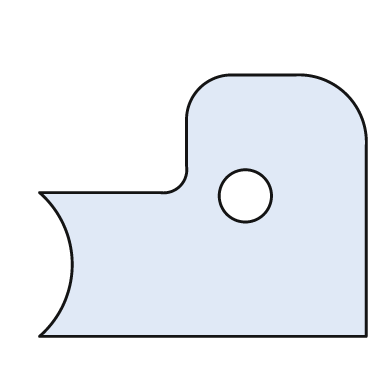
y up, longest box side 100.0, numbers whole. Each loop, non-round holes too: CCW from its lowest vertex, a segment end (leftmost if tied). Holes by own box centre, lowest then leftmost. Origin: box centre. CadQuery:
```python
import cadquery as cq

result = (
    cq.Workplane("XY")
    .moveTo(-50.0, -40.0)
    .lineTo(50.0, -40.0)
    .lineTo(50.0, 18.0)
    .threePointArc((44.0, 34.0), (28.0, 40.0))
    .lineTo(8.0, 40.0)
    .threePointArc((-1.0, 36.0), (-5.0, 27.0))
    .lineTo(-5.0, 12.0)
    .threePointArc((-7.0, 6.0), (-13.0, 4.0))
    .lineTo(-50.0, 4.0)
    .threePointArc((-40.0, -18.0), (-50.0, -40.0))
    .close()
    .moveTo(13.0, 3.0)
    .circle(8.0)
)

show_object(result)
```